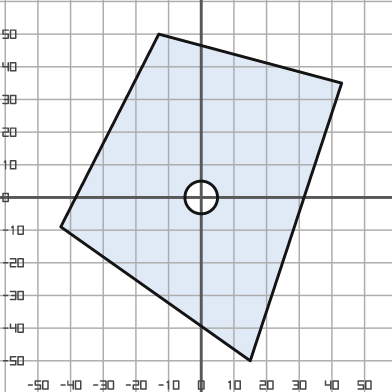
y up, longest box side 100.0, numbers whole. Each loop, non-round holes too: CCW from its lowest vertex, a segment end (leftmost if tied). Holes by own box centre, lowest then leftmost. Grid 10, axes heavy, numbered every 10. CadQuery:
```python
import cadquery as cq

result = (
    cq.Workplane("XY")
    .moveTo(15.0, -50.0)
    .lineTo(43.0, 35.0)
    .lineTo(-13.0, 50.0)
    .lineTo(-43.0, -9.0)
    .close()
    .moveTo(0.0, 0.0)
    .circle(5.0)
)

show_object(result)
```